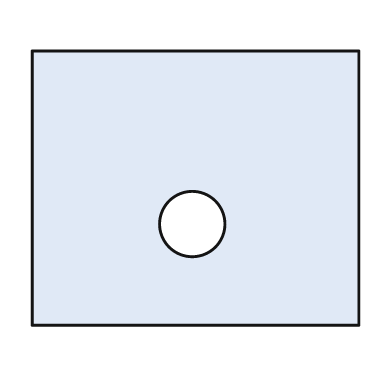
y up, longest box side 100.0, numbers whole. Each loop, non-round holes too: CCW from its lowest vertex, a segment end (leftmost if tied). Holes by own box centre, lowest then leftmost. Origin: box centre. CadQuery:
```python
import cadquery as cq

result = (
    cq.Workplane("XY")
    .moveTo(-50.0, -42.0)
    .lineTo(50.0, -42.0)
    .lineTo(50.0, 42.0)
    .lineTo(-50.0, 42.0)
    .close()
    .moveTo(-1.0, -11.0)
    .circle(10.0)
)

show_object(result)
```